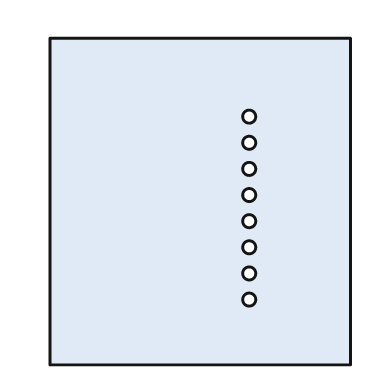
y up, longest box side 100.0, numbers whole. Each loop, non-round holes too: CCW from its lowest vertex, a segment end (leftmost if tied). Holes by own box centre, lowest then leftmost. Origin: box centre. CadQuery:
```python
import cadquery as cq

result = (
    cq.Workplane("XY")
    .moveTo(-46.0, -50.0)
    .lineTo(46.0, -50.0)
    .lineTo(46.0, 50.0)
    .lineTo(-46.0, 50.0)
    .close()
    .moveTo(15.0, -30.0)
    .circle(2.0)
    .moveTo(15.0, -22.0)
    .circle(2.0)
    .moveTo(15.0, -14.0)
    .circle(2.0)
    .moveTo(15.0, -6.0)
    .circle(2.0)
    .moveTo(15.0, 2.0)
    .circle(2.0)
    .moveTo(15.0, 10.0)
    .circle(2.0)
    .moveTo(15.0, 18.0)
    .circle(2.0)
    .moveTo(15.0, 26.0)
    .circle(2.0)
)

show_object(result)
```